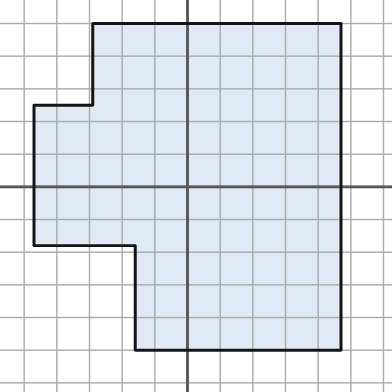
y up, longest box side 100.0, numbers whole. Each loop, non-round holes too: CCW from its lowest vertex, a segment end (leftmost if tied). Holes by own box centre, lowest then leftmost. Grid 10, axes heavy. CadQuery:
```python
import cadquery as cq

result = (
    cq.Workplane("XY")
    .moveTo(-16.0, -50.0)
    .lineTo(47.0, -50.0)
    .lineTo(47.0, 50.0)
    .lineTo(-29.0, 50.0)
    .lineTo(-29.0, 25.0)
    .lineTo(-47.0, 25.0)
    .lineTo(-47.0, -18.0)
    .lineTo(-16.0, -18.0)
    .close()
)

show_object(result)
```